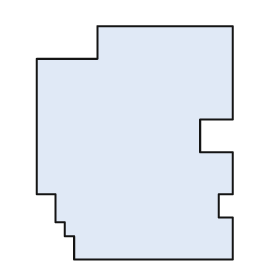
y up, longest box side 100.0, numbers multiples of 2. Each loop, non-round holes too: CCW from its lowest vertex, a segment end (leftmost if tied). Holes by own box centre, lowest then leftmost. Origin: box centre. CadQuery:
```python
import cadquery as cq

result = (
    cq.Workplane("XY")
    .moveTo(-26.0, -50.0)
    .lineTo(42.0, -50.0)
    .lineTo(42.0, -32.0)
    .lineTo(36.0, -32.0)
    .lineTo(36.0, -22.0)
    .lineTo(42.0, -22.0)
    .lineTo(42.0, -4.0)
    .lineTo(28.0, -4.0)
    .lineTo(28.0, 10.0)
    .lineTo(42.0, 10.0)
    .lineTo(42.0, 50.0)
    .lineTo(-16.0, 50.0)
    .lineTo(-16.0, 36.0)
    .lineTo(-42.0, 36.0)
    .lineTo(-42.0, -22.0)
    .lineTo(-34.0, -22.0)
    .lineTo(-34.0, -34.0)
    .lineTo(-30.0, -34.0)
    .lineTo(-30.0, -40.0)
    .lineTo(-26.0, -40.0)
    .close()
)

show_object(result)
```